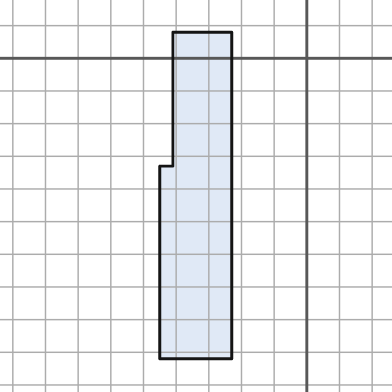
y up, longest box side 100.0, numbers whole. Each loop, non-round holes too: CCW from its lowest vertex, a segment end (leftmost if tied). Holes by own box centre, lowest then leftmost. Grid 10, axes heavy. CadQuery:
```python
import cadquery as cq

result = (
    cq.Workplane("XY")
    .moveTo(-45.0, -92.0)
    .lineTo(-23.0, -92.0)
    .lineTo(-23.0, 8.0)
    .lineTo(-41.0, 8.0)
    .lineTo(-41.0, -33.0)
    .lineTo(-45.0, -33.0)
    .close()
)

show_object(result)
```